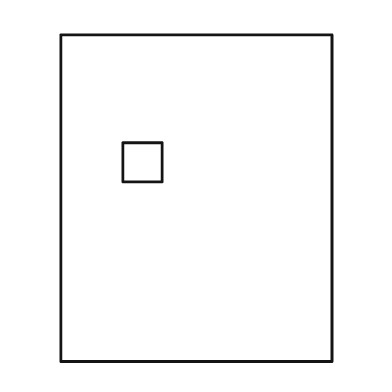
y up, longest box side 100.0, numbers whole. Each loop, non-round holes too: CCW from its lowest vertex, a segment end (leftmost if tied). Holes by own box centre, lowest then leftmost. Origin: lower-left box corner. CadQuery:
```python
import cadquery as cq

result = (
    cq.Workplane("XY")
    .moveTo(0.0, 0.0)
    .lineTo(83.0, 0.0)
    .lineTo(83.0, 100.0)
    .lineTo(0.0, 100.0)
    .close()
    .moveTo(19.0, 55.0)
    .lineTo(31.0, 55.0)
    .lineTo(31.0, 67.0)
    .lineTo(19.0, 67.0)
    .close()
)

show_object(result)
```